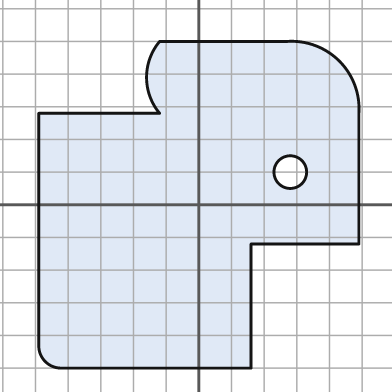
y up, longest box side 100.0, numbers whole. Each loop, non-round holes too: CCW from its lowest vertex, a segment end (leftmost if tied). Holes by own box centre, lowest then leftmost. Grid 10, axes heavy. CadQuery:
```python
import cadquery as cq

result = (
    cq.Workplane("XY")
    .moveTo(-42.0, -50.0)
    .lineTo(16.0, -50.0)
    .lineTo(16.0, -12.0)
    .lineTo(49.0, -12.0)
    .lineTo(49.0, 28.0)
    .threePointArc((43.0, 44.0), (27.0, 50.0))
    .lineTo(-12.0, 50.0)
    .threePointArc((-16.0, 39.0), (-12.0, 28.0))
    .lineTo(-49.0, 28.0)
    .lineTo(-49.0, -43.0)
    .threePointArc((-47.0, -48.0), (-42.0, -50.0))
    .close()
    .moveTo(28.0, 10.0)
    .circle(5.0)
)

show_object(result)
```